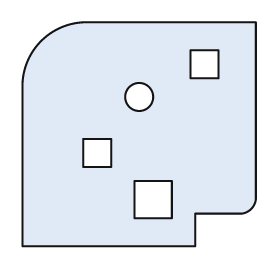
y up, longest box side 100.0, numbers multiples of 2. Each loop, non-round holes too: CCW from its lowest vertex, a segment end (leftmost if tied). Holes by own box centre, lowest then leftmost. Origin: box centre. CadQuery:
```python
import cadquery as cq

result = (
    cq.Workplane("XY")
    .moveTo(-50.0, -48.0)
    .lineTo(24.0, -48.0)
    .lineTo(24.0, -34.0)
    .lineTo(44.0, -34.0)
    .threePointArc((48.0, -32.0), (50.0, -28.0))
    .lineTo(50.0, 48.0)
    .lineTo(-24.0, 48.0)
    .threePointArc((-42.0, 40.0), (-50.0, 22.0))
    .close()
    .moveTo(-2.0, -36.0)
    .lineTo(14.0, -36.0)
    .lineTo(14.0, -20.0)
    .lineTo(-2.0, -20.0)
    .close()
    .moveTo(-24.0, -14.0)
    .lineTo(-12.0, -14.0)
    .lineTo(-12.0, -2.0)
    .lineTo(-24.0, -2.0)
    .close()
    .moveTo(0.0, 16.0)
    .circle(6.0)
    .moveTo(22.0, 24.0)
    .lineTo(34.0, 24.0)
    .lineTo(34.0, 36.0)
    .lineTo(22.0, 36.0)
    .close()
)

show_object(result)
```